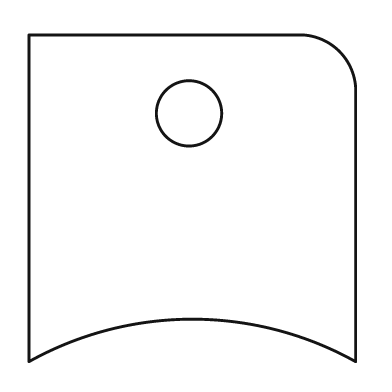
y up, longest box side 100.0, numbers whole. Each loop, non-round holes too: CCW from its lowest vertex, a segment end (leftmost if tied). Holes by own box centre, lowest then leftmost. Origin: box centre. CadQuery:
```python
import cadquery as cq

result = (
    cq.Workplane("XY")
    .moveTo(-50.0, -50.0)
    .threePointArc((0.0, -37.0), (50.0, -50.0))
    .lineTo(50.0, 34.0)
    .threePointArc((45.0, 45.0), (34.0, 50.0))
    .lineTo(-50.0, 50.0)
    .close()
    .moveTo(-1.0, 26.0)
    .circle(10.0)
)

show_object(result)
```